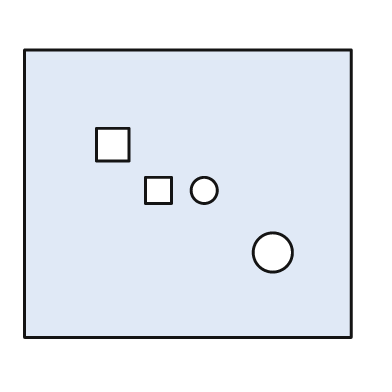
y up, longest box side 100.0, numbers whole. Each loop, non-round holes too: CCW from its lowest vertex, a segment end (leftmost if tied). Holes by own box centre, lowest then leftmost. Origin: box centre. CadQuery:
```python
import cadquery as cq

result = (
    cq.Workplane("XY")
    .moveTo(-50.0, -44.0)
    .lineTo(50.0, -44.0)
    .lineTo(50.0, 44.0)
    .lineTo(-50.0, 44.0)
    .close()
    .moveTo(26.0, -18.0)
    .circle(6.0)
    .moveTo(-13.0, -3.0)
    .lineTo(-5.0, -3.0)
    .lineTo(-5.0, 5.0)
    .lineTo(-13.0, 5.0)
    .close()
    .moveTo(5.0, 1.0)
    .circle(4.0)
    .moveTo(-28.0, 10.0)
    .lineTo(-18.0, 10.0)
    .lineTo(-18.0, 20.0)
    .lineTo(-28.0, 20.0)
    .close()
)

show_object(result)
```